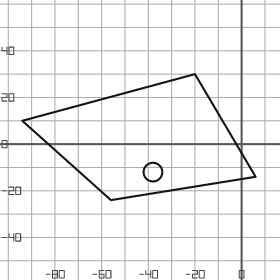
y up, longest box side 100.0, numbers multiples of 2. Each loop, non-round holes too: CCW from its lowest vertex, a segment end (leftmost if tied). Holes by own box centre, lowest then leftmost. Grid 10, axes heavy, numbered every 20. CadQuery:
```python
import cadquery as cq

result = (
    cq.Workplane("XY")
    .moveTo(-56.0, -24.0)
    .lineTo(6.0, -14.0)
    .lineTo(-20.0, 30.0)
    .lineTo(-94.0, 10.0)
    .close()
    .moveTo(-38.0, -12.0)
    .circle(4.0)
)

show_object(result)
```